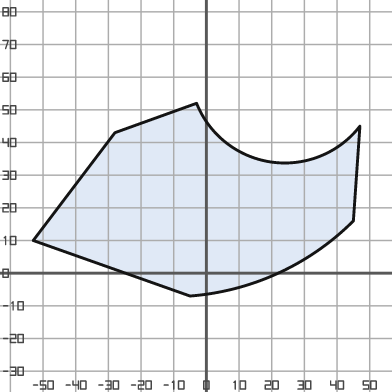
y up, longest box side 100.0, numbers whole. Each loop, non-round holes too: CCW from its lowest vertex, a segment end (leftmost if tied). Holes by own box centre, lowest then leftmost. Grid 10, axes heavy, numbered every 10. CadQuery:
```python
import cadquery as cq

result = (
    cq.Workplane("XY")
    .moveTo(-5.0, -7.0)
    .threePointArc((22.0, 0.0), (45.0, 16.0))
    .lineTo(47.0, 45.0)
    .threePointArc((20.0, 34.0), (-3.0, 52.0))
    .lineTo(-28.0, 43.0)
    .lineTo(-53.0, 10.0)
    .close()
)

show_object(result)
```